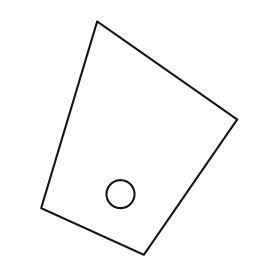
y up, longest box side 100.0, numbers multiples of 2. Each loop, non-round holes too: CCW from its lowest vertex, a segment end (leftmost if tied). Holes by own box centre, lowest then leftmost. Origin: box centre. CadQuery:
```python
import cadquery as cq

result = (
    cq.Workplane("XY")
    .moveTo(2.0, -50.0)
    .lineTo(42.0, 8.0)
    .lineTo(-18.0, 50.0)
    .lineTo(-42.0, -30.0)
    .close()
    .moveTo(-8.0, -24.0)
    .circle(6.0)
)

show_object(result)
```